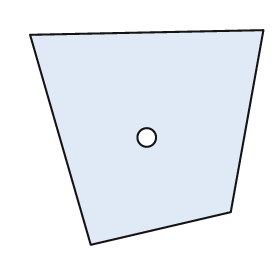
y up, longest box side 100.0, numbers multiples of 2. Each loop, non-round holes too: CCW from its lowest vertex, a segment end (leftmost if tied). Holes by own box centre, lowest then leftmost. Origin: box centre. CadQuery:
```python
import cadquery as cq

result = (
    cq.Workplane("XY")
    .moveTo(-24.0, -46.0)
    .lineTo(36.0, -32.0)
    .lineTo(50.0, 46.0)
    .lineTo(-50.0, 44.0)
    .close()
    .moveTo(0.0, 0.0)
    .circle(4.0)
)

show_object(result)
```